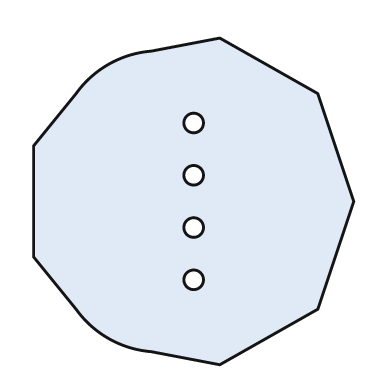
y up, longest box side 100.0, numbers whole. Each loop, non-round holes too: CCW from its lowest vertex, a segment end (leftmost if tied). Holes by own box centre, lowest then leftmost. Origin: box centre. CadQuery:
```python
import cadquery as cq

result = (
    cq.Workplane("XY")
    .moveTo(8.0, -50.0)
    .lineTo(38.0, -33.0)
    .lineTo(49.0, 0.0)
    .lineTo(38.0, 33.0)
    .lineTo(8.0, 50.0)
    .lineTo(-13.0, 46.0)
    .threePointArc((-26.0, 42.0), (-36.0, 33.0))
    .lineTo(-49.0, 17.0)
    .lineTo(-49.0, -17.0)
    .lineTo(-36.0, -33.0)
    .threePointArc((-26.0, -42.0), (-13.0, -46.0))
    .close()
    .moveTo(0.0, -24.0)
    .circle(3.0)
    .moveTo(0.0, -8.0)
    .circle(3.0)
    .moveTo(0.0, 8.0)
    .circle(3.0)
    .moveTo(0.0, 24.0)
    .circle(3.0)
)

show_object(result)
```